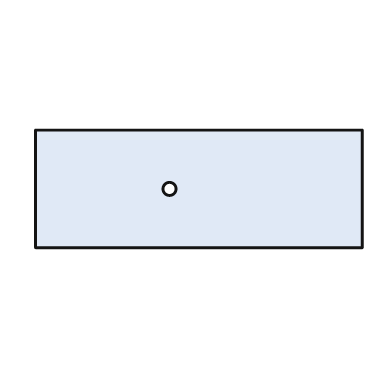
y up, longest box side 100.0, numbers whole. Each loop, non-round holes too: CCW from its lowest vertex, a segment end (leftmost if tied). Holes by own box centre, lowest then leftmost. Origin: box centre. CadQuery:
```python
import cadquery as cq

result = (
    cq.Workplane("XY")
    .moveTo(-50.0, -18.0)
    .lineTo(50.0, -18.0)
    .lineTo(50.0, 18.0)
    .lineTo(-50.0, 18.0)
    .close()
    .moveTo(-9.0, 0.0)
    .circle(2.0)
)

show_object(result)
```